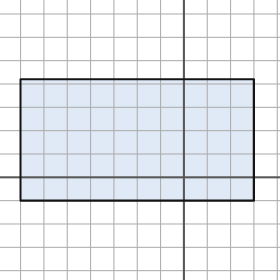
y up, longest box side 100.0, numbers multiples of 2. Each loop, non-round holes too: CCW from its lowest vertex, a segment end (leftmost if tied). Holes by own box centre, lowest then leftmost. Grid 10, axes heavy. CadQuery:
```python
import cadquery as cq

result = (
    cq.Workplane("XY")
    .moveTo(-70.0, -10.0)
    .lineTo(30.0, -10.0)
    .lineTo(30.0, 42.0)
    .lineTo(-70.0, 42.0)
    .close()
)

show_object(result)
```